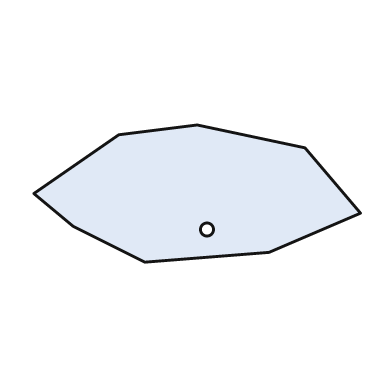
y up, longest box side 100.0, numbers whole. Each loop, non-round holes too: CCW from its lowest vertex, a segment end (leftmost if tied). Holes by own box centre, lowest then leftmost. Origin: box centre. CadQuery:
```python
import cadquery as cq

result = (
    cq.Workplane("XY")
    .moveTo(-16.0, -21.0)
    .lineTo(22.0, -18.0)
    .lineTo(50.0, -6.0)
    .lineTo(33.0, 14.0)
    .lineTo(0.0, 21.0)
    .lineTo(-24.0, 18.0)
    .lineTo(-50.0, 0.0)
    .lineTo(-38.0, -10.0)
    .close()
    .moveTo(3.0, -11.0)
    .circle(2.0)
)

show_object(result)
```